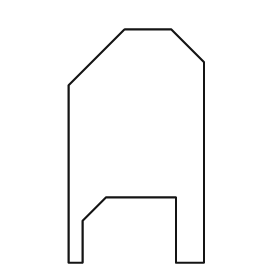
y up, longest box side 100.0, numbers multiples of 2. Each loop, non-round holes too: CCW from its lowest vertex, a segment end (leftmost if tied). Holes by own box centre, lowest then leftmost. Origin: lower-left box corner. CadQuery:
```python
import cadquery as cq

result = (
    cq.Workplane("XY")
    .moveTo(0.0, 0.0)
    .lineTo(6.0, 0.0)
    .lineTo(6.0, 18.0)
    .lineTo(16.0, 28.0)
    .lineTo(46.0, 28.0)
    .lineTo(46.0, 0.0)
    .lineTo(58.0, 0.0)
    .lineTo(58.0, 86.0)
    .lineTo(44.0, 100.0)
    .lineTo(24.0, 100.0)
    .lineTo(0.0, 76.0)
    .close()
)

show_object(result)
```